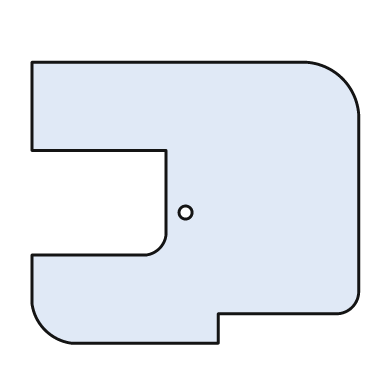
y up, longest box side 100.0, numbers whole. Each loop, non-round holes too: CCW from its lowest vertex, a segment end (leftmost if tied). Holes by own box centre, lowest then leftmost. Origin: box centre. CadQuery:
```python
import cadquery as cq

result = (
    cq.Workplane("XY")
    .moveTo(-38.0, -43.0)
    .lineTo(7.0, -43.0)
    .lineTo(7.0, -34.0)
    .lineTo(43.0, -34.0)
    .threePointArc((48.0, -32.0), (50.0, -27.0))
    .lineTo(50.0, 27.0)
    .threePointArc((45.0, 38.0), (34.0, 43.0))
    .lineTo(-50.0, 43.0)
    .lineTo(-50.0, 16.0)
    .lineTo(-9.0, 16.0)
    .lineTo(-9.0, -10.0)
    .threePointArc((-11.0, -14.0), (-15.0, -16.0))
    .lineTo(-50.0, -16.0)
    .lineTo(-50.0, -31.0)
    .threePointArc((-46.0, -39.0), (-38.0, -43.0))
    .close()
    .moveTo(-3.0, -3.0)
    .circle(2.0)
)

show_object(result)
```